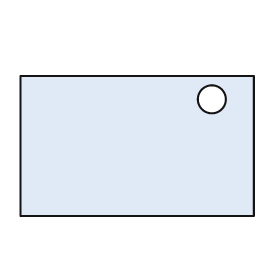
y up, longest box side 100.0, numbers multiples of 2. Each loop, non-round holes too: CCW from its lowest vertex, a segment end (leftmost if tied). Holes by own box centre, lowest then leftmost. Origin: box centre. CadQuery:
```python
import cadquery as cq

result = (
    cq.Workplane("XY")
    .moveTo(-50.0, -30.0)
    .lineTo(50.0, -30.0)
    .lineTo(50.0, 30.0)
    .lineTo(-50.0, 30.0)
    .close()
    .moveTo(32.0, 20.0)
    .circle(6.0)
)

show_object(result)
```